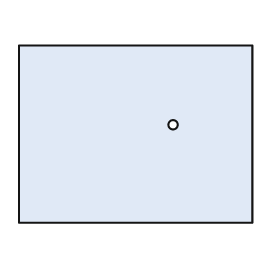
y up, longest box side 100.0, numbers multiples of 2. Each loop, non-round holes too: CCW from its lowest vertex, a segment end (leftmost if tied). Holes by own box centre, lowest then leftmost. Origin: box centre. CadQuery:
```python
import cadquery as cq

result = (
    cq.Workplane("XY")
    .moveTo(-50.0, -38.0)
    .lineTo(50.0, -38.0)
    .lineTo(50.0, 38.0)
    .lineTo(-50.0, 38.0)
    .close()
    .moveTo(16.0, 4.0)
    .circle(2.0)
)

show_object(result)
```